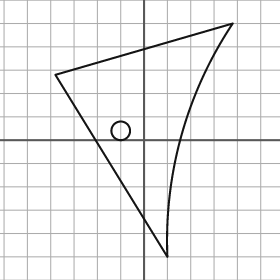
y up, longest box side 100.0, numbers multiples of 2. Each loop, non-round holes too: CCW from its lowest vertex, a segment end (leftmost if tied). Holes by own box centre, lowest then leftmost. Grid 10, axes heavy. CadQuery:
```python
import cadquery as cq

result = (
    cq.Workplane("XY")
    .moveTo(10.0, -50.0)
    .threePointArc((16.0, 2.0), (38.0, 50.0))
    .lineTo(-38.0, 28.0)
    .close()
    .moveTo(-10.0, 4.0)
    .circle(4.0)
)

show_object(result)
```